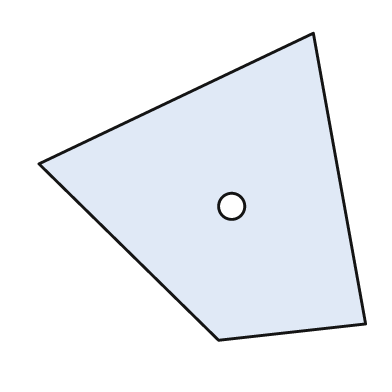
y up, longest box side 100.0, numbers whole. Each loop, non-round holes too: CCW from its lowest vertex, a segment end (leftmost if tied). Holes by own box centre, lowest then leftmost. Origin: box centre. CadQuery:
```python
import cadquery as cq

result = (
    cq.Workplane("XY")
    .moveTo(5.0, -47.0)
    .lineTo(50.0, -42.0)
    .lineTo(34.0, 47.0)
    .lineTo(-50.0, 7.0)
    .close()
    .moveTo(9.0, -6.0)
    .circle(4.0)
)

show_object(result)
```